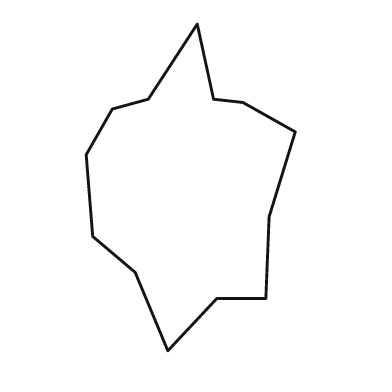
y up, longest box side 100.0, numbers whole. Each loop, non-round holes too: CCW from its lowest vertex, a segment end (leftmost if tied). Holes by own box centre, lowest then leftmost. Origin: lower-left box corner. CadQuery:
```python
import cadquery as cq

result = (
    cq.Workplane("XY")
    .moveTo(25.0, 0.0)
    .lineTo(40.0, 16.0)
    .lineTo(55.0, 16.0)
    .lineTo(56.0, 41.0)
    .lineTo(64.0, 67.0)
    .lineTo(48.0, 76.0)
    .lineTo(39.0, 77.0)
    .lineTo(34.0, 100.0)
    .lineTo(19.0, 77.0)
    .lineTo(8.0, 74.0)
    .lineTo(0.0, 60.0)
    .lineTo(2.0, 35.0)
    .lineTo(15.0, 24.0)
    .close()
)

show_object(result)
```